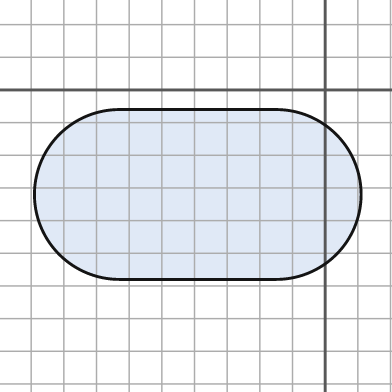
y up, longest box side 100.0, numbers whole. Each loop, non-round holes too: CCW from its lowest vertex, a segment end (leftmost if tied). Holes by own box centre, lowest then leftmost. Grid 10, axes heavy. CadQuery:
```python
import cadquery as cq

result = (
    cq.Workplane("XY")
    .moveTo(-63.0, -58.0)
    .lineTo(-15.0, -58.0)
    .threePointArc((11.0, -32.0), (-15.0, -6.0))
    .lineTo(-63.0, -6.0)
    .threePointArc((-89.0, -32.0), (-63.0, -58.0))
    .close()
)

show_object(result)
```